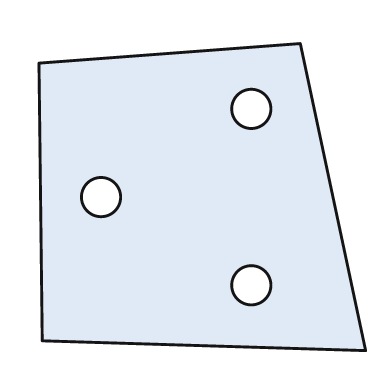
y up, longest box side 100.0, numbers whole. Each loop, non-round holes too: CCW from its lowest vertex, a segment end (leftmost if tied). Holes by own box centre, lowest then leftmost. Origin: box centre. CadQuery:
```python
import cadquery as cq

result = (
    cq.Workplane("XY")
    .moveTo(50.0, -47.0)
    .lineTo(30.0, 47.0)
    .lineTo(-50.0, 41.0)
    .lineTo(-49.0, -44.0)
    .close()
    .moveTo(15.0, -27.0)
    .circle(6.0)
    .moveTo(-31.0, 0.0)
    .circle(6.0)
    .moveTo(15.0, 27.0)
    .circle(6.0)
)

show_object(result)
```